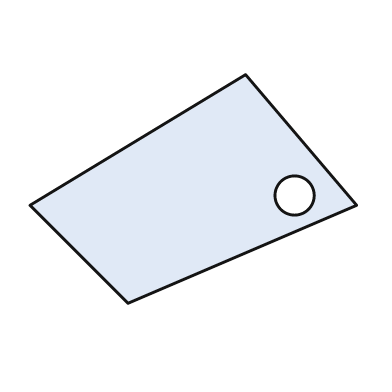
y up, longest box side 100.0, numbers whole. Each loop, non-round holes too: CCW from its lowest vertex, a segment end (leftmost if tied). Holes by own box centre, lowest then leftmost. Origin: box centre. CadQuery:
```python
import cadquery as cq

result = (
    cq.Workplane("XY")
    .moveTo(-20.0, -35.0)
    .lineTo(50.0, -5.0)
    .lineTo(16.0, 35.0)
    .lineTo(-50.0, -5.0)
    .close()
    .moveTo(31.0, -2.0)
    .circle(6.0)
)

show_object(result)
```